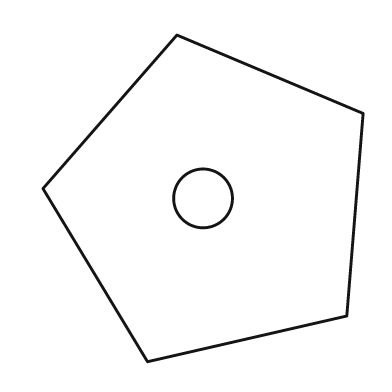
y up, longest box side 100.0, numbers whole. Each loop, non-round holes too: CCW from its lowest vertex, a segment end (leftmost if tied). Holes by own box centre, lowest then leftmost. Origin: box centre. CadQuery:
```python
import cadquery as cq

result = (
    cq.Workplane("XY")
    .moveTo(-17.0, -50.0)
    .lineTo(44.0, -36.0)
    .lineTo(49.0, 26.0)
    .lineTo(-8.0, 50.0)
    .lineTo(-49.0, 3.0)
    .close()
    .moveTo(0.0, 0.0)
    .circle(9.0)
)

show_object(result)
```